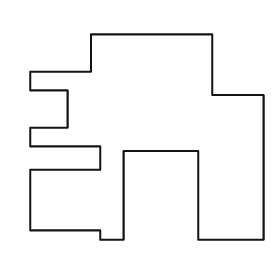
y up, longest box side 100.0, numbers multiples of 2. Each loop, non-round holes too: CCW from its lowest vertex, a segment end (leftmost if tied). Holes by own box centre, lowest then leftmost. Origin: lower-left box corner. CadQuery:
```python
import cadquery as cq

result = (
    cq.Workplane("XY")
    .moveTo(30.0, 0.0)
    .lineTo(40.0, 0.0)
    .lineTo(40.0, 38.0)
    .lineTo(72.0, 38.0)
    .lineTo(72.0, 0.0)
    .lineTo(100.0, 0.0)
    .lineTo(100.0, 62.0)
    .lineTo(78.0, 62.0)
    .lineTo(78.0, 88.0)
    .lineTo(26.0, 88.0)
    .lineTo(26.0, 72.0)
    .lineTo(0.0, 72.0)
    .lineTo(0.0, 64.0)
    .lineTo(16.0, 64.0)
    .lineTo(16.0, 48.0)
    .lineTo(0.0, 48.0)
    .lineTo(0.0, 40.0)
    .lineTo(30.0, 40.0)
    .lineTo(30.0, 30.0)
    .lineTo(0.0, 30.0)
    .lineTo(0.0, 4.0)
    .lineTo(30.0, 4.0)
    .close()
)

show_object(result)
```